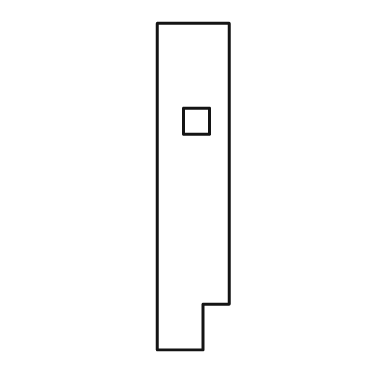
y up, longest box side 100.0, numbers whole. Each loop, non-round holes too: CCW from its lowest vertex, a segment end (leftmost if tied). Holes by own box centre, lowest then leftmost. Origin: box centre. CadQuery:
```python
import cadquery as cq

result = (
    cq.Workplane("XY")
    .moveTo(-11.0, -50.0)
    .lineTo(3.0, -50.0)
    .lineTo(3.0, -36.0)
    .lineTo(11.0, -36.0)
    .lineTo(11.0, 50.0)
    .lineTo(-11.0, 50.0)
    .close()
    .moveTo(-3.0, 16.0)
    .lineTo(5.0, 16.0)
    .lineTo(5.0, 24.0)
    .lineTo(-3.0, 24.0)
    .close()
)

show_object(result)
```